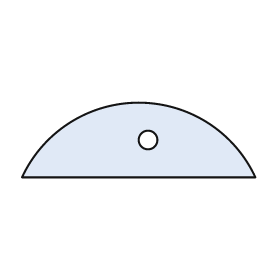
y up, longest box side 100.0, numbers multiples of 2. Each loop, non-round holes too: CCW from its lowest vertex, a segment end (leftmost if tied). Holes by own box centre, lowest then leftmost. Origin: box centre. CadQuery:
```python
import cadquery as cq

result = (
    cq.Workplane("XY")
    .moveTo(-50.0, -16.0)
    .lineTo(50.0, -16.0)
    .threePointArc((0.0, 16.0), (-50.0, -16.0))
    .close()
    .moveTo(4.0, 0.0)
    .circle(4.0)
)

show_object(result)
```